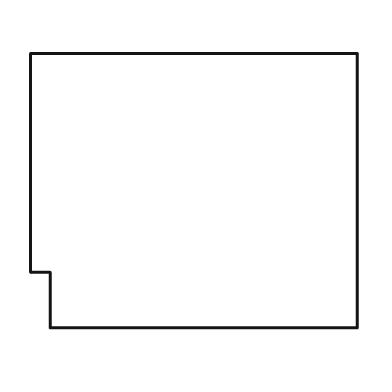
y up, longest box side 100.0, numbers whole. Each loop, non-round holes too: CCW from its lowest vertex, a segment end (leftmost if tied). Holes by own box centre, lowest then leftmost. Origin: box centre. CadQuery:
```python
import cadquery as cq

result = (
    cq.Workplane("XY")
    .moveTo(-44.0, -42.0)
    .lineTo(50.0, -42.0)
    .lineTo(50.0, 42.0)
    .lineTo(-50.0, 42.0)
    .lineTo(-50.0, -25.0)
    .lineTo(-44.0, -25.0)
    .close()
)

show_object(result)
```